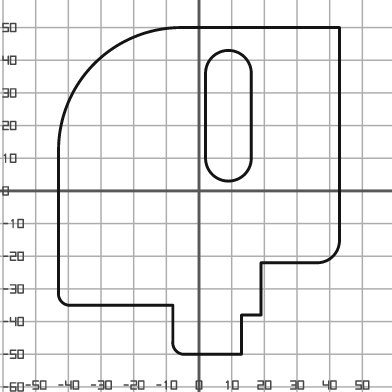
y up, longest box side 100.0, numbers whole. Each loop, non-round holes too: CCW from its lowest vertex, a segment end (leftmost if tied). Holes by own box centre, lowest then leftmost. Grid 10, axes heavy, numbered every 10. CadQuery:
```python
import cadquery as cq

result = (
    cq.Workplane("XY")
    .moveTo(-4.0, -50.0)
    .lineTo(13.0, -50.0)
    .lineTo(13.0, -38.0)
    .lineTo(19.0, -38.0)
    .lineTo(19.0, -22.0)
    .lineTo(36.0, -22.0)
    .threePointArc((41.0, -20.0), (43.0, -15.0))
    .lineTo(43.0, 50.0)
    .lineTo(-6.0, 50.0)
    .threePointArc((-32.0, 39.0), (-43.0, 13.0))
    .lineTo(-43.0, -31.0)
    .threePointArc((-42.0, -34.0), (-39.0, -35.0))
    .lineTo(-8.0, -35.0)
    .lineTo(-8.0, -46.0)
    .threePointArc((-7.0, -49.0), (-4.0, -50.0))
    .close()
    .moveTo(2.0, 10.0)
    .threePointArc((9.0, 3.0), (16.0, 10.0))
    .lineTo(16.0, 36.0)
    .threePointArc((9.0, 43.0), (2.0, 36.0))
    .close()
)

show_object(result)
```